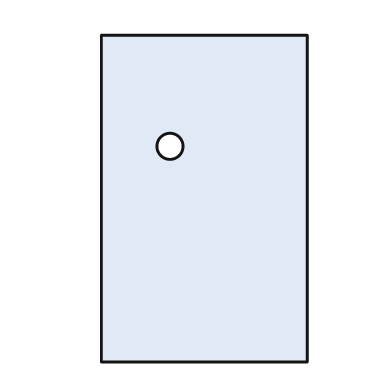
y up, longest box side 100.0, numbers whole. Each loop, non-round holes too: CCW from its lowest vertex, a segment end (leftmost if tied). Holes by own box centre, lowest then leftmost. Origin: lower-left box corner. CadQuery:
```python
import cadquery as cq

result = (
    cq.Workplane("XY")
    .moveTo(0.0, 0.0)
    .lineTo(63.0, 0.0)
    .lineTo(63.0, 100.0)
    .lineTo(0.0, 100.0)
    .close()
    .moveTo(21.0, 66.0)
    .circle(4.0)
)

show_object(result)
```